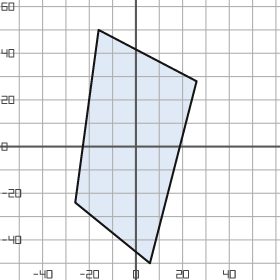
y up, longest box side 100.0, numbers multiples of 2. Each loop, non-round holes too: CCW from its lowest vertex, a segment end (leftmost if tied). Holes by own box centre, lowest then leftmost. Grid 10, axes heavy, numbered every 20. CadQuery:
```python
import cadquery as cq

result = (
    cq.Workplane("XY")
    .moveTo(6.0, -50.0)
    .lineTo(26.0, 28.0)
    .lineTo(-16.0, 50.0)
    .lineTo(-26.0, -24.0)
    .close()
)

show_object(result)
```